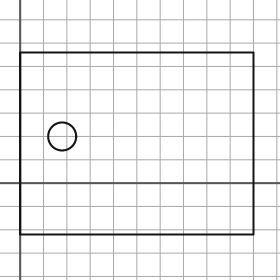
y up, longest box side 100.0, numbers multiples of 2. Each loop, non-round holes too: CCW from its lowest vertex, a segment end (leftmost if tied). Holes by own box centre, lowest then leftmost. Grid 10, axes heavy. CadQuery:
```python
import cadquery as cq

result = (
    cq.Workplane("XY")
    .moveTo(0.0, -22.0)
    .lineTo(100.0, -22.0)
    .lineTo(100.0, 56.0)
    .lineTo(0.0, 56.0)
    .close()
    .moveTo(18.0, 20.0)
    .circle(6.0)
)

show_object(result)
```